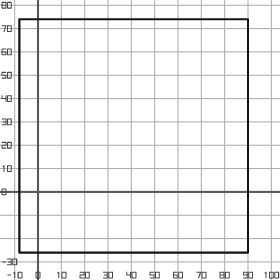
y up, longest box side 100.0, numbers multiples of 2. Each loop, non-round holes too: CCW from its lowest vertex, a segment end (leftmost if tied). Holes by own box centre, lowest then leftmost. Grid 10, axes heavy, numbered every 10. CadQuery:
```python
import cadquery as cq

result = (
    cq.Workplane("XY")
    .moveTo(-8.0, -26.0)
    .lineTo(90.0, -26.0)
    .lineTo(90.0, 74.0)
    .lineTo(-8.0, 74.0)
    .close()
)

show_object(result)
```